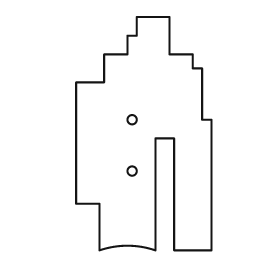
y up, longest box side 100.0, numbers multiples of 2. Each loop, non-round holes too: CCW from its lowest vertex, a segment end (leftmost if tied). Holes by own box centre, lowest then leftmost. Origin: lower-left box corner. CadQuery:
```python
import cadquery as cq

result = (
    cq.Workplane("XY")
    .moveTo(10.0, 0.0)
    .threePointArc((22.0, 2.0), (34.0, 0.0))
    .lineTo(34.0, 48.0)
    .lineTo(42.0, 48.0)
    .lineTo(42.0, 0.0)
    .lineTo(58.0, 0.0)
    .lineTo(58.0, 56.0)
    .lineTo(54.0, 56.0)
    .lineTo(54.0, 78.0)
    .lineTo(50.0, 78.0)
    .lineTo(50.0, 84.0)
    .lineTo(40.0, 84.0)
    .lineTo(40.0, 100.0)
    .lineTo(26.0, 100.0)
    .lineTo(26.0, 92.0)
    .lineTo(22.0, 92.0)
    .lineTo(22.0, 84.0)
    .lineTo(12.0, 84.0)
    .lineTo(12.0, 72.0)
    .lineTo(0.0, 72.0)
    .lineTo(0.0, 20.0)
    .lineTo(10.0, 20.0)
    .close()
    .moveTo(24.0, 34.0)
    .circle(2.0)
    .moveTo(24.0, 56.0)
    .circle(2.0)
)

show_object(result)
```